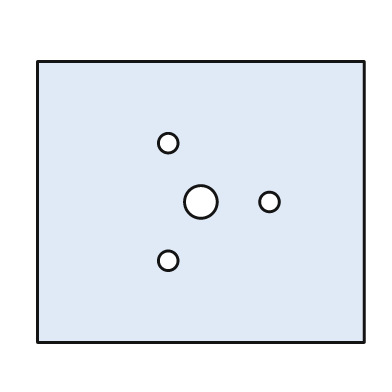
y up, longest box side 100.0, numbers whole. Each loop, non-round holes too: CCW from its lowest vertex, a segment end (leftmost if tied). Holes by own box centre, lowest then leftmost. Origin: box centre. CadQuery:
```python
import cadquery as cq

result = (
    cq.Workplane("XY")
    .moveTo(-50.0, -43.0)
    .lineTo(50.0, -43.0)
    .lineTo(50.0, 43.0)
    .lineTo(-50.0, 43.0)
    .close()
    .moveTo(-10.0, -18.0)
    .circle(3.0)
    .moveTo(0.0, 0.0)
    .circle(5.0)
    .moveTo(21.0, 0.0)
    .circle(3.0)
    .moveTo(-10.0, 18.0)
    .circle(3.0)
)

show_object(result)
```